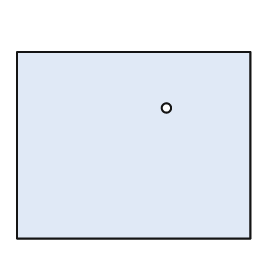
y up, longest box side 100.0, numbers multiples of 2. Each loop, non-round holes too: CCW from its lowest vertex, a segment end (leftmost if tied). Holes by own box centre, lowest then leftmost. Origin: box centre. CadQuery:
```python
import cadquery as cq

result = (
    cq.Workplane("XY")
    .moveTo(-50.0, -40.0)
    .lineTo(50.0, -40.0)
    .lineTo(50.0, 40.0)
    .lineTo(-50.0, 40.0)
    .close()
    .moveTo(14.0, 16.0)
    .circle(2.0)
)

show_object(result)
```